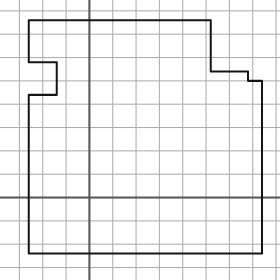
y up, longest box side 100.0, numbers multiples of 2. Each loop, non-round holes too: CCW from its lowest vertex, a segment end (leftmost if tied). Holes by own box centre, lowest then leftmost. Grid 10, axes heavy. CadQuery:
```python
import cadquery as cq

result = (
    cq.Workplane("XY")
    .moveTo(-26.0, -24.0)
    .lineTo(74.0, -24.0)
    .lineTo(74.0, 50.0)
    .lineTo(68.0, 50.0)
    .lineTo(68.0, 54.0)
    .lineTo(52.0, 54.0)
    .lineTo(52.0, 76.0)
    .lineTo(-26.0, 76.0)
    .lineTo(-26.0, 58.0)
    .lineTo(-14.0, 58.0)
    .lineTo(-14.0, 44.0)
    .lineTo(-26.0, 44.0)
    .close()
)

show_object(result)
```